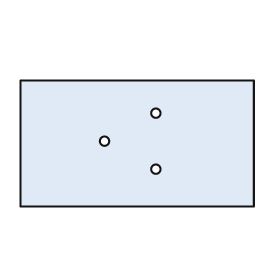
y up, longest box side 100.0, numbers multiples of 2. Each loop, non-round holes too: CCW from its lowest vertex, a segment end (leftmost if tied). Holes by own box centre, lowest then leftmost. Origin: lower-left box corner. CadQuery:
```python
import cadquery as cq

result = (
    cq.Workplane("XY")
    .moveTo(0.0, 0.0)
    .lineTo(100.0, 0.0)
    .lineTo(100.0, 54.0)
    .lineTo(0.0, 54.0)
    .close()
    .moveTo(58.0, 16.0)
    .circle(2.0)
    .moveTo(36.0, 28.0)
    .circle(2.0)
    .moveTo(58.0, 40.0)
    .circle(2.0)
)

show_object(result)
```